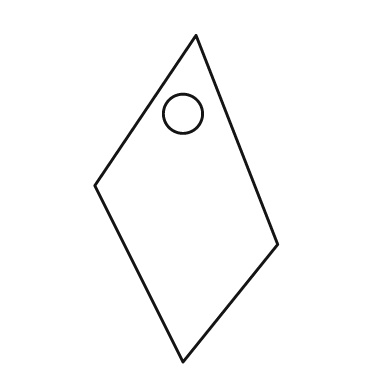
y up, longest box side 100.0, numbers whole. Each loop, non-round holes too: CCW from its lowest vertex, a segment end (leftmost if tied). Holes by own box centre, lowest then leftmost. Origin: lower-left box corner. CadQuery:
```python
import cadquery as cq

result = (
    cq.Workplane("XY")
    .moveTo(27.0, 0.0)
    .lineTo(56.0, 36.0)
    .lineTo(31.0, 100.0)
    .lineTo(0.0, 54.0)
    .close()
    .moveTo(27.0, 76.0)
    .circle(6.0)
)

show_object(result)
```